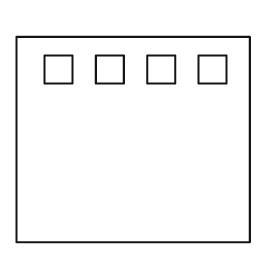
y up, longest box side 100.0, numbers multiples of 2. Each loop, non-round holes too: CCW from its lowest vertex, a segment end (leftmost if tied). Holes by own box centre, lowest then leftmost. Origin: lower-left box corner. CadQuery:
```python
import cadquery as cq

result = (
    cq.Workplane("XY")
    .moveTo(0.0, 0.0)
    .lineTo(100.0, 0.0)
    .lineTo(100.0, 88.0)
    .lineTo(0.0, 88.0)
    .close()
    .moveTo(12.0, 68.0)
    .lineTo(24.0, 68.0)
    .lineTo(24.0, 80.0)
    .lineTo(12.0, 80.0)
    .close()
    .moveTo(34.0, 68.0)
    .lineTo(46.0, 68.0)
    .lineTo(46.0, 80.0)
    .lineTo(34.0, 80.0)
    .close()
    .moveTo(56.0, 68.0)
    .lineTo(68.0, 68.0)
    .lineTo(68.0, 80.0)
    .lineTo(56.0, 80.0)
    .close()
    .moveTo(78.0, 68.0)
    .lineTo(90.0, 68.0)
    .lineTo(90.0, 80.0)
    .lineTo(78.0, 80.0)
    .close()
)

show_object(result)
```